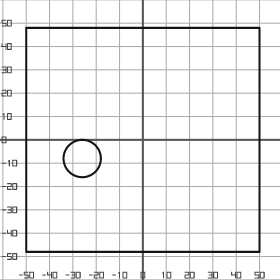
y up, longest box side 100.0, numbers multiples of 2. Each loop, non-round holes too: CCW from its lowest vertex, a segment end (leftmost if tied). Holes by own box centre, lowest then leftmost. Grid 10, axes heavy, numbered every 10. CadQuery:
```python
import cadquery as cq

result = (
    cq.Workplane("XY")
    .moveTo(-50.0, -48.0)
    .lineTo(50.0, -48.0)
    .lineTo(50.0, 48.0)
    .lineTo(-50.0, 48.0)
    .close()
    .moveTo(-26.0, -8.0)
    .circle(8.0)
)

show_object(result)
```